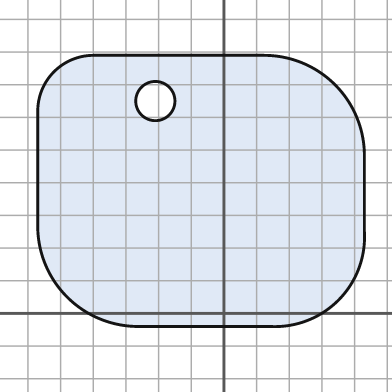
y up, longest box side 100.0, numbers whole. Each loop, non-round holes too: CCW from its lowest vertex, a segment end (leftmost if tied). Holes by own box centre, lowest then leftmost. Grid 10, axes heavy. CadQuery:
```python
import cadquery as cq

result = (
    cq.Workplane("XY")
    .moveTo(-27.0, -4.0)
    .lineTo(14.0, -4.0)
    .threePointArc((35.0, 4.0), (43.0, 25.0))
    .lineTo(43.0, 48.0)
    .threePointArc((34.0, 70.0), (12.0, 79.0))
    .lineTo(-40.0, 79.0)
    .threePointArc((-52.0, 74.0), (-57.0, 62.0))
    .lineTo(-57.0, 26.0)
    .threePointArc((-48.0, 5.0), (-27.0, -4.0))
    .close()
    .moveTo(-21.0, 65.0)
    .circle(6.0)
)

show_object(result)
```